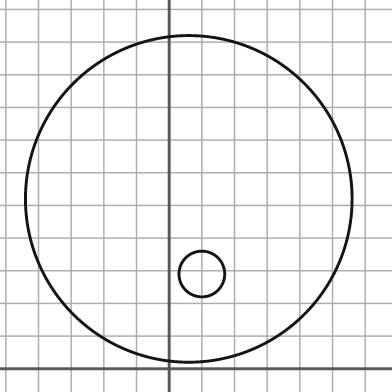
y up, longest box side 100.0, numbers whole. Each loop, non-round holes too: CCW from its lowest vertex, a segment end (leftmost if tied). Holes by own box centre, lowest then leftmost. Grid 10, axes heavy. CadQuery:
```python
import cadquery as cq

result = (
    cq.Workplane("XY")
    .moveTo(6.0, 52.0)
    .circle(50.0)
    .moveTo(10.0, 29.0)
    .circle(7.0)
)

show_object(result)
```